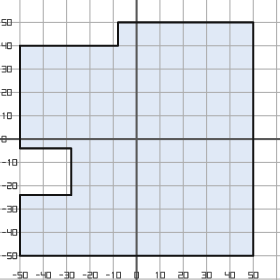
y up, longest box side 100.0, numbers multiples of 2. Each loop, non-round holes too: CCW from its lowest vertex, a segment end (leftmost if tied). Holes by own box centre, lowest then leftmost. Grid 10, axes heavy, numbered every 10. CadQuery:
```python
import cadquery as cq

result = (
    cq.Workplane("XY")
    .moveTo(-50.0, -50.0)
    .lineTo(50.0, -50.0)
    .lineTo(50.0, 50.0)
    .lineTo(-8.0, 50.0)
    .lineTo(-8.0, 40.0)
    .lineTo(-50.0, 40.0)
    .lineTo(-50.0, -4.0)
    .lineTo(-28.0, -4.0)
    .lineTo(-28.0, -24.0)
    .lineTo(-50.0, -24.0)
    .close()
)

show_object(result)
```